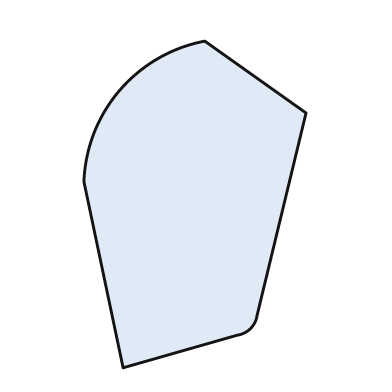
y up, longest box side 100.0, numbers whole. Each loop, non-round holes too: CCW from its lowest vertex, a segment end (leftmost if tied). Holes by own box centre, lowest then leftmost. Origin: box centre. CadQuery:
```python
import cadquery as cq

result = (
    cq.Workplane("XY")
    .moveTo(-22.0, -50.0)
    .lineTo(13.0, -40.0)
    .threePointArc((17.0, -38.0), (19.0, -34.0))
    .lineTo(34.0, 28.0)
    .lineTo(3.0, 50.0)
    .threePointArc((-23.0, 35.0), (-34.0, 7.0))
    .close()
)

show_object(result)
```